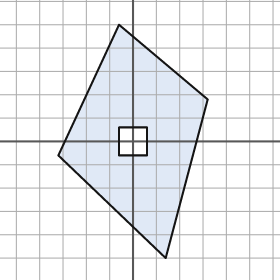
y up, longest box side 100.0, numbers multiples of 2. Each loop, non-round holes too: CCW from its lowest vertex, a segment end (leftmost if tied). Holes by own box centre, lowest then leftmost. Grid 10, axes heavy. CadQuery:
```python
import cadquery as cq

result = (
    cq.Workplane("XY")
    .moveTo(14.0, -50.0)
    .lineTo(32.0, 18.0)
    .lineTo(-6.0, 50.0)
    .lineTo(-32.0, -6.0)
    .close()
    .moveTo(-6.0, -6.0)
    .lineTo(6.0, -6.0)
    .lineTo(6.0, 6.0)
    .lineTo(-6.0, 6.0)
    .close()
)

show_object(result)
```